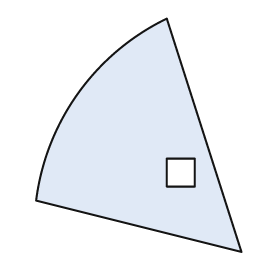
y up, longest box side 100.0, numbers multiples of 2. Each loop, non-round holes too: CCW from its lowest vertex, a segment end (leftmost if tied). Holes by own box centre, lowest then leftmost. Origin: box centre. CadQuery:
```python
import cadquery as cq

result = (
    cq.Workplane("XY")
    .moveTo(44.0, -50.0)
    .lineTo(12.0, 50.0)
    .threePointArc((-26.0, 18.0), (-44.0, -28.0))
    .close()
    .moveTo(12.0, -22.0)
    .lineTo(24.0, -22.0)
    .lineTo(24.0, -10.0)
    .lineTo(12.0, -10.0)
    .close()
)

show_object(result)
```